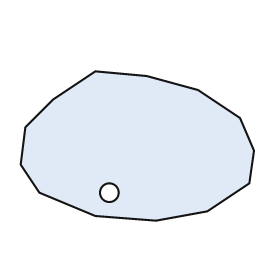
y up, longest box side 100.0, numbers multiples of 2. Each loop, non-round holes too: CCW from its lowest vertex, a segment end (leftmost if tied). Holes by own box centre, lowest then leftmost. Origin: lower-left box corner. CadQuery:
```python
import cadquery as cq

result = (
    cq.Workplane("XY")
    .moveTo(58.0, 0.0)
    .lineTo(80.0, 4.0)
    .lineTo(98.0, 16.0)
    .lineTo(100.0, 30.0)
    .lineTo(94.0, 44.0)
    .lineTo(76.0, 56.0)
    .lineTo(54.0, 62.0)
    .lineTo(32.0, 64.0)
    .lineTo(14.0, 52.0)
    .lineTo(2.0, 40.0)
    .lineTo(0.0, 24.0)
    .lineTo(8.0, 12.0)
    .lineTo(32.0, 2.0)
    .close()
    .moveTo(38.0, 12.0)
    .circle(4.0)
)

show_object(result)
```